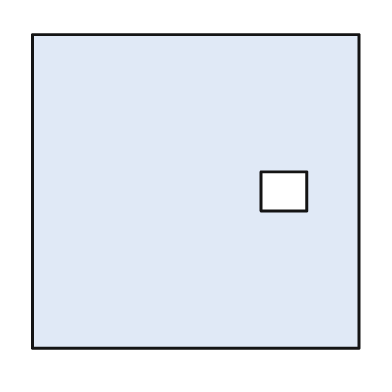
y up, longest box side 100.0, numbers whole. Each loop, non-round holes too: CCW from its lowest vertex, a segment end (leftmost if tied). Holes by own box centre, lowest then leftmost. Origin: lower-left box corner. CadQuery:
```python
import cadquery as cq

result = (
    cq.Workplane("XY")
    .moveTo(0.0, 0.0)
    .lineTo(100.0, 0.0)
    .lineTo(100.0, 96.0)
    .lineTo(0.0, 96.0)
    .close()
    .moveTo(70.0, 42.0)
    .lineTo(84.0, 42.0)
    .lineTo(84.0, 54.0)
    .lineTo(70.0, 54.0)
    .close()
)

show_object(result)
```